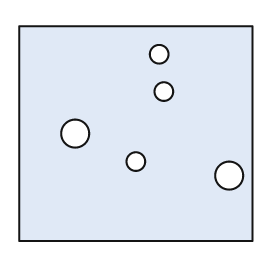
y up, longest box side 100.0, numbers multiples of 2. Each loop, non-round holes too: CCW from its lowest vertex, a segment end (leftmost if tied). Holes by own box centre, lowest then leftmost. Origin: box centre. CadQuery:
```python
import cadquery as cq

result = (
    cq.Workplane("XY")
    .moveTo(-50.0, -46.0)
    .lineTo(50.0, -46.0)
    .lineTo(50.0, 46.0)
    .lineTo(-50.0, 46.0)
    .close()
    .moveTo(40.0, -18.0)
    .circle(6.0)
    .moveTo(0.0, -12.0)
    .circle(4.0)
    .moveTo(-26.0, 0.0)
    .circle(6.0)
    .moveTo(12.0, 18.0)
    .circle(4.0)
    .moveTo(10.0, 34.0)
    .circle(4.0)
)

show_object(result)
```